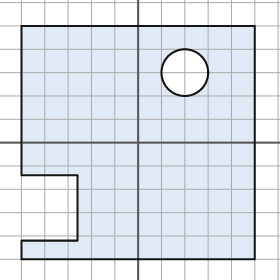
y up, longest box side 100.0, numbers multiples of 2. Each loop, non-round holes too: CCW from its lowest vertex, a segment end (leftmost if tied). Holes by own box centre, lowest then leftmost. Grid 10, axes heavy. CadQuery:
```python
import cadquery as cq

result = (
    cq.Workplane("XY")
    .moveTo(-50.0, -50.0)
    .lineTo(50.0, -50.0)
    .lineTo(50.0, 50.0)
    .lineTo(-50.0, 50.0)
    .lineTo(-50.0, -14.0)
    .lineTo(-26.0, -14.0)
    .lineTo(-26.0, -42.0)
    .lineTo(-50.0, -42.0)
    .close()
    .moveTo(20.0, 30.0)
    .circle(10.0)
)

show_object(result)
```